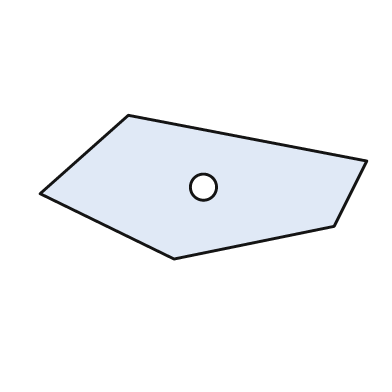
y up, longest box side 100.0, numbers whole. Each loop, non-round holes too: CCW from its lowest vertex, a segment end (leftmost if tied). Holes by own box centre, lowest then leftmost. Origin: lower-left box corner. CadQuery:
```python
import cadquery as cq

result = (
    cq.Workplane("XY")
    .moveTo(41.0, 0.0)
    .lineTo(90.0, 10.0)
    .lineTo(100.0, 30.0)
    .lineTo(27.0, 44.0)
    .lineTo(0.0, 20.0)
    .close()
    .moveTo(50.0, 22.0)
    .circle(4.0)
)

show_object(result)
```